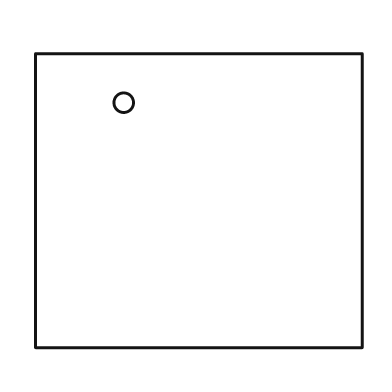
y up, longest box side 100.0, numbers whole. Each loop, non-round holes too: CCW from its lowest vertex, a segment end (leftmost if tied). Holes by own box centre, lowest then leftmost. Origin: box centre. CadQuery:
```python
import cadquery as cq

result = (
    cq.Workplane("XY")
    .moveTo(-50.0, -45.0)
    .lineTo(50.0, -45.0)
    .lineTo(50.0, 45.0)
    .lineTo(-50.0, 45.0)
    .close()
    .moveTo(-23.0, 30.0)
    .circle(3.0)
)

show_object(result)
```